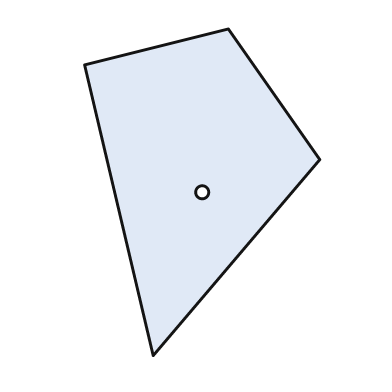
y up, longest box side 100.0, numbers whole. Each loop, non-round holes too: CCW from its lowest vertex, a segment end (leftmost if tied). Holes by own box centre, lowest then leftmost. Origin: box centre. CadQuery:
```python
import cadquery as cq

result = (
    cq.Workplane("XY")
    .moveTo(-15.0, -50.0)
    .lineTo(36.0, 10.0)
    .lineTo(8.0, 50.0)
    .lineTo(-36.0, 39.0)
    .close()
    .moveTo(0.0, 0.0)
    .circle(2.0)
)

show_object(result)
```